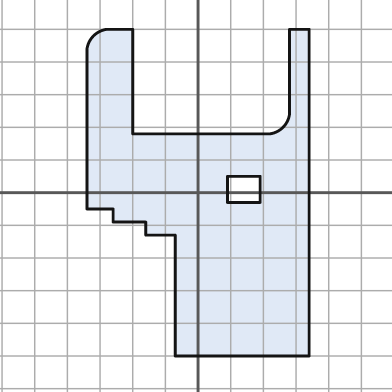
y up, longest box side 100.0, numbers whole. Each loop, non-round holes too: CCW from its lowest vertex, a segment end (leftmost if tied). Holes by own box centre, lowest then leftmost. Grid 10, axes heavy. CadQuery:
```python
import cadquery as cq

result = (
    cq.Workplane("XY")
    .moveTo(-7.0, -50.0)
    .lineTo(34.0, -50.0)
    .lineTo(34.0, 50.0)
    .lineTo(28.0, 50.0)
    .lineTo(28.0, 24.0)
    .threePointArc((26.0, 20.0), (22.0, 18.0))
    .lineTo(-20.0, 18.0)
    .lineTo(-20.0, 50.0)
    .lineTo(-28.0, 50.0)
    .threePointArc((-32.0, 48.0), (-34.0, 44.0))
    .lineTo(-34.0, -5.0)
    .lineTo(-26.0, -5.0)
    .lineTo(-26.0, -9.0)
    .lineTo(-16.0, -9.0)
    .lineTo(-16.0, -13.0)
    .lineTo(-7.0, -13.0)
    .close()
    .moveTo(9.0, -3.0)
    .lineTo(19.0, -3.0)
    .lineTo(19.0, 5.0)
    .lineTo(9.0, 5.0)
    .close()
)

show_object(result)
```